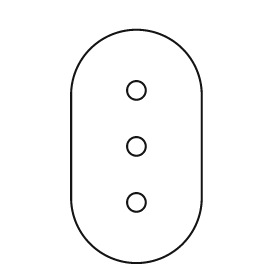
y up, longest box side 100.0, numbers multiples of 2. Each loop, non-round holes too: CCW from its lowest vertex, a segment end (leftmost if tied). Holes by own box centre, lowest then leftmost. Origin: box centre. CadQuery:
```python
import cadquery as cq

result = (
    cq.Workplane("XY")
    .moveTo(-28.0, -22.0)
    .threePointArc((0.0, -50.0), (28.0, -22.0))
    .lineTo(28.0, 22.0)
    .threePointArc((0.0, 50.0), (-28.0, 22.0))
    .close()
    .moveTo(0.0, -24.0)
    .circle(4.0)
    .moveTo(0.0, 0.0)
    .circle(4.0)
    .moveTo(0.0, 24.0)
    .circle(4.0)
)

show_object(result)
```